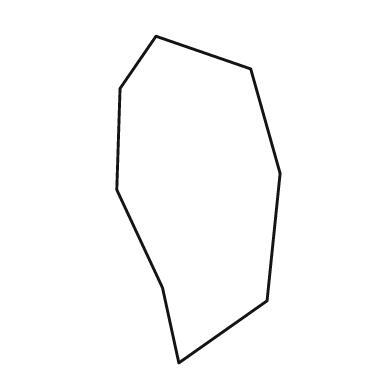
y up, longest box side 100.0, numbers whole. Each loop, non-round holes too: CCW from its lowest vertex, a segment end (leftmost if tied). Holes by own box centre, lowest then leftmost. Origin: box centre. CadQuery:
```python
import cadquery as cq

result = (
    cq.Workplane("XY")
    .moveTo(-6.0, -50.0)
    .lineTo(21.0, -31.0)
    .lineTo(25.0, 8.0)
    .lineTo(16.0, 40.0)
    .lineTo(-13.0, 50.0)
    .lineTo(-24.0, 34.0)
    .lineTo(-25.0, 3.0)
    .lineTo(-11.0, -27.0)
    .close()
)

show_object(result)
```